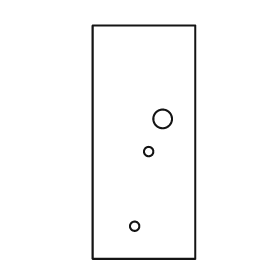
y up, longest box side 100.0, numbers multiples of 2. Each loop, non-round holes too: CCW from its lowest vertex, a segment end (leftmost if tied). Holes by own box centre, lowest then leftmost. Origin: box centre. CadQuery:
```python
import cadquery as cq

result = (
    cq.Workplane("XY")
    .moveTo(-22.0, -50.0)
    .lineTo(22.0, -50.0)
    .lineTo(22.0, 50.0)
    .lineTo(-22.0, 50.0)
    .close()
    .moveTo(-4.0, -36.0)
    .circle(2.0)
    .moveTo(2.0, -4.0)
    .circle(2.0)
    .moveTo(8.0, 10.0)
    .circle(4.0)
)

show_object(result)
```